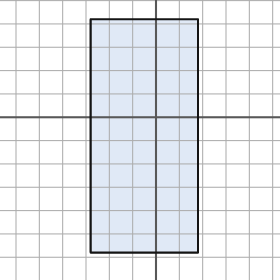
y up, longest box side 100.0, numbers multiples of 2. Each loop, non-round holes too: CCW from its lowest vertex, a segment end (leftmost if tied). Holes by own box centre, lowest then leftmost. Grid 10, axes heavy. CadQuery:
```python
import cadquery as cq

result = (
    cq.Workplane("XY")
    .moveTo(-28.0, -58.0)
    .lineTo(18.0, -58.0)
    .lineTo(18.0, 42.0)
    .lineTo(-28.0, 42.0)
    .close()
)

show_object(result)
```